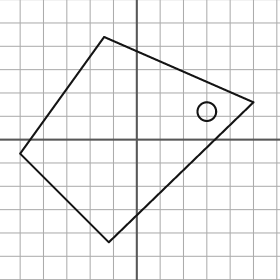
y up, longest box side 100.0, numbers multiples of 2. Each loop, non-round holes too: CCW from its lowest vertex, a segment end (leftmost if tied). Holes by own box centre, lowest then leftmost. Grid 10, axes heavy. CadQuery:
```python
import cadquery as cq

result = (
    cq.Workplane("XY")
    .moveTo(-12.0, -44.0)
    .lineTo(50.0, 16.0)
    .lineTo(-14.0, 44.0)
    .lineTo(-50.0, -6.0)
    .close()
    .moveTo(30.0, 12.0)
    .circle(4.0)
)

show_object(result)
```